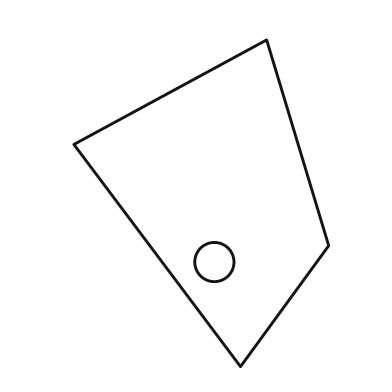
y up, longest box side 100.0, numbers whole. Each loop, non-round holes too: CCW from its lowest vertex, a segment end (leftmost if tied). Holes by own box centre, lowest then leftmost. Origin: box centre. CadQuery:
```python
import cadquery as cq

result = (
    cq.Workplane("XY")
    .moveTo(12.0, -50.0)
    .lineTo(39.0, -13.0)
    .lineTo(20.0, 50.0)
    .lineTo(-39.0, 18.0)
    .close()
    .moveTo(4.0, -18.0)
    .circle(6.0)
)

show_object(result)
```